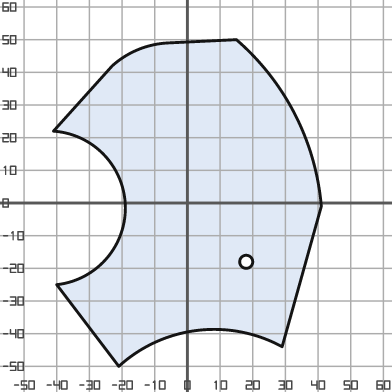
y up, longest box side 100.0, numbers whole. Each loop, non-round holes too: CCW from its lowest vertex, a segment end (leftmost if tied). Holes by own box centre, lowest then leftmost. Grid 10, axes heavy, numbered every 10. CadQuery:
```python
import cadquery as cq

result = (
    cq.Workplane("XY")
    .moveTo(-21.0, -50.0)
    .threePointArc((3.0, -39.0), (29.0, -44.0))
    .lineTo(41.0, -1.0)
    .threePointArc((33.0, 27.0), (15.0, 50.0))
    .lineTo(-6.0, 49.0)
    .threePointArc((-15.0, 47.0), (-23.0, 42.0))
    .lineTo(-41.0, 22.0)
    .threePointArc((-19.0, -1.0), (-40.0, -25.0))
    .close()
    .moveTo(18.0, -18.0)
    .circle(2.0)
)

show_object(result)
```